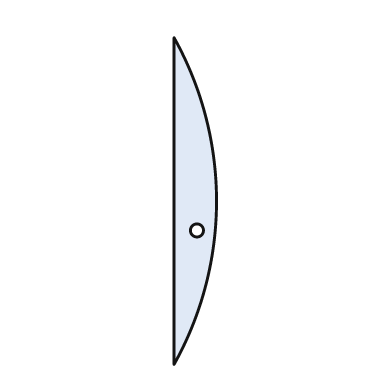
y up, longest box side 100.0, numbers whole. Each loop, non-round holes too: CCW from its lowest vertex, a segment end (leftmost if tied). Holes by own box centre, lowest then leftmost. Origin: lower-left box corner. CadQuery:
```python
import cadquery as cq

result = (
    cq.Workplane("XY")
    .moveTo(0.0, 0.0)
    .threePointArc((13.0, 50.0), (0.0, 100.0))
    .close()
    .moveTo(7.0, 41.0)
    .circle(2.0)
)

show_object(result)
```